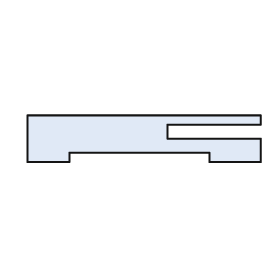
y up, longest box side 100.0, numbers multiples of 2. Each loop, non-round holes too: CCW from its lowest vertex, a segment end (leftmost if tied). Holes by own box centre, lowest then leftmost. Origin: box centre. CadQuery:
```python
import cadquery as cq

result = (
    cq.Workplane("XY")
    .moveTo(-50.0, -10.0)
    .lineTo(-32.0, -10.0)
    .lineTo(-32.0, -6.0)
    .lineTo(28.0, -6.0)
    .lineTo(28.0, -10.0)
    .lineTo(50.0, -10.0)
    .lineTo(50.0, 0.0)
    .lineTo(10.0, 0.0)
    .lineTo(10.0, 6.0)
    .lineTo(50.0, 6.0)
    .lineTo(50.0, 10.0)
    .lineTo(-50.0, 10.0)
    .close()
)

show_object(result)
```